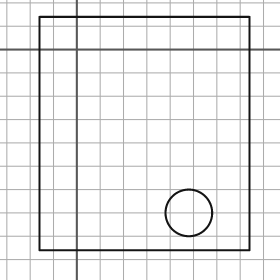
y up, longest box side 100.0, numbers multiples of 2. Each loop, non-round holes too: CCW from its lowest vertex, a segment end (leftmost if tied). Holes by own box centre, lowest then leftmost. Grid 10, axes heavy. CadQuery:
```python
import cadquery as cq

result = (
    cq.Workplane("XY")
    .moveTo(-16.0, -86.0)
    .lineTo(74.0, -86.0)
    .lineTo(74.0, 14.0)
    .lineTo(-16.0, 14.0)
    .close()
    .moveTo(48.0, -70.0)
    .circle(10.0)
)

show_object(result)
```